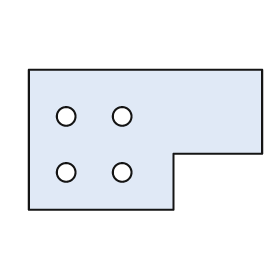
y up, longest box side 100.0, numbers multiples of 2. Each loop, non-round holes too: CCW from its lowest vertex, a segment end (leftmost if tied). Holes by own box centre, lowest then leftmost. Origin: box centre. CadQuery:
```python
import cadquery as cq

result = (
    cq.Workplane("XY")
    .moveTo(-50.0, -30.0)
    .lineTo(12.0, -30.0)
    .lineTo(12.0, -6.0)
    .lineTo(50.0, -6.0)
    .lineTo(50.0, 30.0)
    .lineTo(-50.0, 30.0)
    .close()
    .moveTo(-34.0, -14.0)
    .circle(4.0)
    .moveTo(-10.0, -14.0)
    .circle(4.0)
    .moveTo(-34.0, 10.0)
    .circle(4.0)
    .moveTo(-10.0, 10.0)
    .circle(4.0)
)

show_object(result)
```